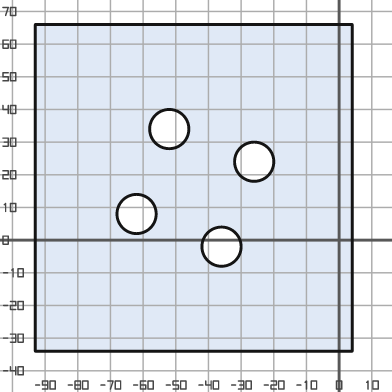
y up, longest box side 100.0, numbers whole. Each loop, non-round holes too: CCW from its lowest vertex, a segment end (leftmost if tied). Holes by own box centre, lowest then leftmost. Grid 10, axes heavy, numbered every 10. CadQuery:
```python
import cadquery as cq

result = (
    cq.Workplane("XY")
    .moveTo(-93.0, -34.0)
    .lineTo(4.0, -34.0)
    .lineTo(4.0, 66.0)
    .lineTo(-93.0, 66.0)
    .close()
    .moveTo(-36.0, -2.0)
    .circle(6.0)
    .moveTo(-62.0, 8.0)
    .circle(6.0)
    .moveTo(-26.0, 24.0)
    .circle(6.0)
    .moveTo(-52.0, 34.0)
    .circle(6.0)
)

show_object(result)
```